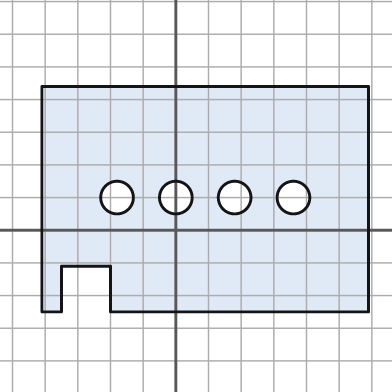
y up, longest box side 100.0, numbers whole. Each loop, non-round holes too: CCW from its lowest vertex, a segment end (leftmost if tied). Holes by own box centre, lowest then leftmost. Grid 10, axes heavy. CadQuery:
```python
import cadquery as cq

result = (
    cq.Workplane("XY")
    .moveTo(-41.0, -25.0)
    .lineTo(-35.0, -25.0)
    .lineTo(-35.0, -11.0)
    .lineTo(-20.0, -11.0)
    .lineTo(-20.0, -25.0)
    .lineTo(59.0, -25.0)
    .lineTo(59.0, 44.0)
    .lineTo(-41.0, 44.0)
    .close()
    .moveTo(-18.0, 10.0)
    .circle(5.0)
    .moveTo(0.0, 10.0)
    .circle(5.0)
    .moveTo(18.0, 10.0)
    .circle(5.0)
    .moveTo(36.0, 10.0)
    .circle(5.0)
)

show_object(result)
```